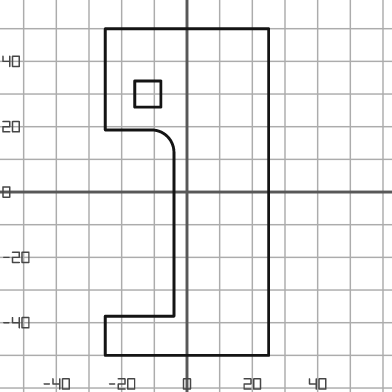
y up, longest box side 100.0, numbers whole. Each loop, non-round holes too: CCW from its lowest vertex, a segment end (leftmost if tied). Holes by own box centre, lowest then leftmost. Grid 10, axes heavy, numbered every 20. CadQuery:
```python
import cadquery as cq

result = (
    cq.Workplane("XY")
    .moveTo(-25.0, -50.0)
    .lineTo(25.0, -50.0)
    .lineTo(25.0, 50.0)
    .lineTo(-25.0, 50.0)
    .lineTo(-25.0, 19.0)
    .lineTo(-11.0, 19.0)
    .threePointArc((-6.0, 17.0), (-4.0, 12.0))
    .lineTo(-4.0, -38.0)
    .lineTo(-25.0, -38.0)
    .close()
    .moveTo(-16.0, 26.0)
    .lineTo(-8.0, 26.0)
    .lineTo(-8.0, 34.0)
    .lineTo(-16.0, 34.0)
    .close()
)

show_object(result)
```